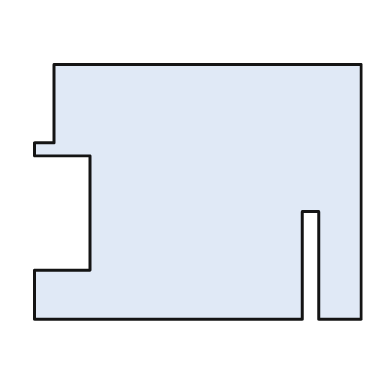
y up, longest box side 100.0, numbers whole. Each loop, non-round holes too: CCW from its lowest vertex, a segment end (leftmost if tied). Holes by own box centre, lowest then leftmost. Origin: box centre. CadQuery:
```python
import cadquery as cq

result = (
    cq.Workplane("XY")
    .moveTo(-50.0, -39.0)
    .lineTo(32.0, -39.0)
    .lineTo(32.0, -6.0)
    .lineTo(37.0, -6.0)
    .lineTo(37.0, -39.0)
    .lineTo(50.0, -39.0)
    .lineTo(50.0, 39.0)
    .lineTo(-44.0, 39.0)
    .lineTo(-44.0, 15.0)
    .lineTo(-50.0, 15.0)
    .lineTo(-50.0, 11.0)
    .lineTo(-33.0, 11.0)
    .lineTo(-33.0, -24.0)
    .lineTo(-50.0, -24.0)
    .close()
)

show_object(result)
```